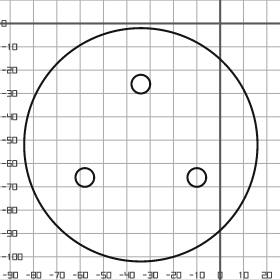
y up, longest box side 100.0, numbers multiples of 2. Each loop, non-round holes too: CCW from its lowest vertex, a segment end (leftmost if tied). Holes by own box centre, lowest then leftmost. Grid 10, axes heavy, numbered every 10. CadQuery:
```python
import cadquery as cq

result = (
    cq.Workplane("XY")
    .moveTo(-34.0, -52.0)
    .circle(50.0)
    .moveTo(-58.0, -66.0)
    .circle(4.0)
    .moveTo(-10.0, -66.0)
    .circle(4.0)
    .moveTo(-34.0, -26.0)
    .circle(4.0)
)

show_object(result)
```